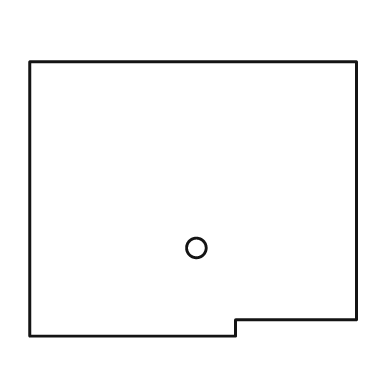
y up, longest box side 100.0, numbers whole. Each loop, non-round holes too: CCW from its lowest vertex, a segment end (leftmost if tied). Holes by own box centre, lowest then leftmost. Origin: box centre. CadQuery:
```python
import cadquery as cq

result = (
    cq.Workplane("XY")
    .moveTo(-50.0, -42.0)
    .lineTo(13.0, -42.0)
    .lineTo(13.0, -37.0)
    .lineTo(50.0, -37.0)
    .lineTo(50.0, 42.0)
    .lineTo(-50.0, 42.0)
    .close()
    .moveTo(1.0, -15.0)
    .circle(3.0)
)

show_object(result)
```